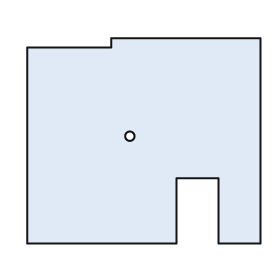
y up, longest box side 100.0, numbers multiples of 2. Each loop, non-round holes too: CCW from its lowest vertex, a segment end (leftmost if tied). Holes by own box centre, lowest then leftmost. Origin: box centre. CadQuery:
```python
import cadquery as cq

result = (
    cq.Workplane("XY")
    .moveTo(-50.0, -44.0)
    .lineTo(14.0, -44.0)
    .lineTo(14.0, -16.0)
    .lineTo(32.0, -16.0)
    .lineTo(32.0, -44.0)
    .lineTo(50.0, -44.0)
    .lineTo(50.0, 44.0)
    .lineTo(-14.0, 44.0)
    .lineTo(-14.0, 40.0)
    .lineTo(-50.0, 40.0)
    .close()
    .moveTo(-6.0, 2.0)
    .circle(2.0)
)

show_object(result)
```